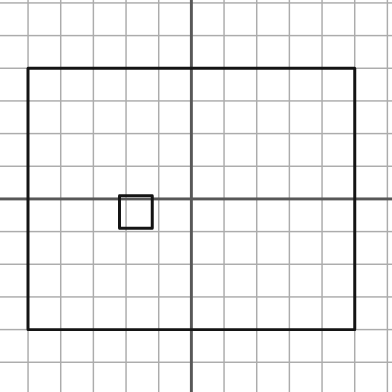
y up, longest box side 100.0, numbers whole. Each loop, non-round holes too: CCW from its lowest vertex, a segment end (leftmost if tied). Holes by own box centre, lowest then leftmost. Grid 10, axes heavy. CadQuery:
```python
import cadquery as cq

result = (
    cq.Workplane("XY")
    .moveTo(-50.0, -40.0)
    .lineTo(50.0, -40.0)
    .lineTo(50.0, 40.0)
    .lineTo(-50.0, 40.0)
    .close()
    .moveTo(-22.0, -9.0)
    .lineTo(-12.0, -9.0)
    .lineTo(-12.0, 1.0)
    .lineTo(-22.0, 1.0)
    .close()
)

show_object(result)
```